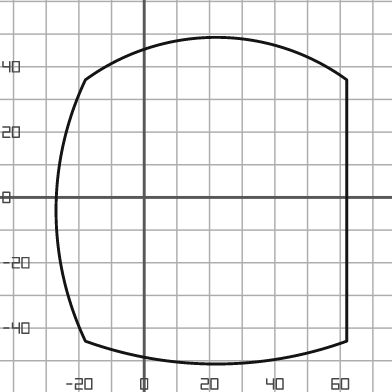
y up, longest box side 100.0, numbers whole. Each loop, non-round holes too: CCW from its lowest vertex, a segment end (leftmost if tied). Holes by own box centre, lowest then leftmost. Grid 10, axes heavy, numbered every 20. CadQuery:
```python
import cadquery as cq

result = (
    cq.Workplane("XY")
    .moveTo(-18.0, -44.0)
    .threePointArc((22.0, -51.0), (62.0, -44.0))
    .lineTo(62.0, 36.0)
    .threePointArc((22.0, 49.0), (-18.0, 36.0))
    .threePointArc((-27.0, -4.0), (-18.0, -44.0))
    .close()
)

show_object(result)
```